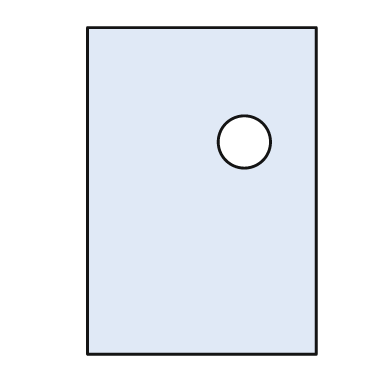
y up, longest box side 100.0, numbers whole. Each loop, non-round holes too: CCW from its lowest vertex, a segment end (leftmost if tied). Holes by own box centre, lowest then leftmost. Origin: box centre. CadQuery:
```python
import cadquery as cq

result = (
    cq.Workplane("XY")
    .moveTo(-35.0, -50.0)
    .lineTo(35.0, -50.0)
    .lineTo(35.0, 50.0)
    .lineTo(-35.0, 50.0)
    .close()
    .moveTo(13.0, 15.0)
    .circle(8.0)
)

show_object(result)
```